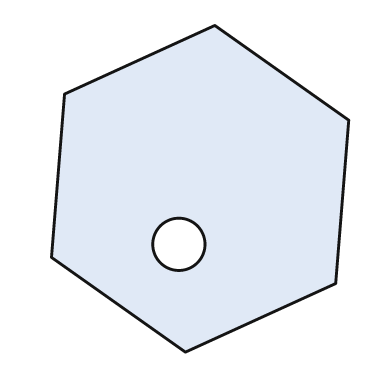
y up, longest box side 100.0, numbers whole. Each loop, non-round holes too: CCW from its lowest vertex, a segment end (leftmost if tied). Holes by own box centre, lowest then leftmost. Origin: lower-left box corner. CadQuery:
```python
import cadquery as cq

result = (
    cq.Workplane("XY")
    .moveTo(41.0, 0.0)
    .lineTo(87.0, 21.0)
    .lineTo(91.0, 71.0)
    .lineTo(50.0, 100.0)
    .lineTo(4.0, 79.0)
    .lineTo(0.0, 29.0)
    .close()
    .moveTo(39.0, 33.0)
    .circle(8.0)
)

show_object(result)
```